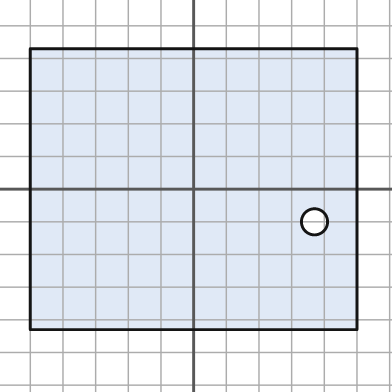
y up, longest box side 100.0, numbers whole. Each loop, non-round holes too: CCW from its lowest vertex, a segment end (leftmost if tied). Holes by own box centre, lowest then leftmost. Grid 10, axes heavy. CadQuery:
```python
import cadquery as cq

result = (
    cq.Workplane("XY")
    .moveTo(-50.0, -43.0)
    .lineTo(50.0, -43.0)
    .lineTo(50.0, 43.0)
    .lineTo(-50.0, 43.0)
    .close()
    .moveTo(37.0, -10.0)
    .circle(4.0)
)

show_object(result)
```